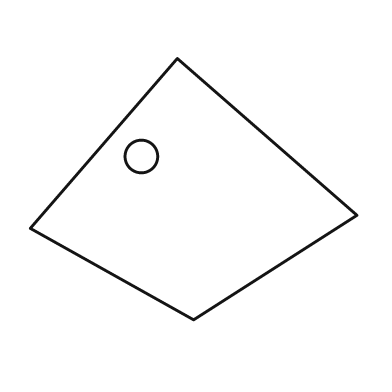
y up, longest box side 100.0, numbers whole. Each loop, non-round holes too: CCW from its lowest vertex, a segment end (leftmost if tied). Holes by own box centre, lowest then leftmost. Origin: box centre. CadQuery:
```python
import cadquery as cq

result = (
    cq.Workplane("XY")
    .moveTo(0.0, -40.0)
    .lineTo(50.0, -8.0)
    .lineTo(-5.0, 40.0)
    .lineTo(-50.0, -12.0)
    .close()
    .moveTo(-16.0, 10.0)
    .circle(5.0)
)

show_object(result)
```